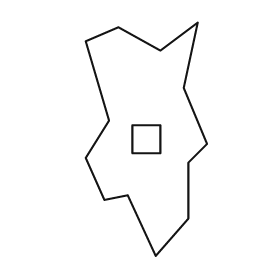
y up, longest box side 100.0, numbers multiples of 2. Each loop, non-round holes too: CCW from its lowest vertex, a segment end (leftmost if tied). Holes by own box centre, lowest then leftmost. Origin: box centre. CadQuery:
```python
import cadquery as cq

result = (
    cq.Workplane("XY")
    .moveTo(4.0, -50.0)
    .lineTo(18.0, -34.0)
    .lineTo(18.0, -10.0)
    .lineTo(26.0, -2.0)
    .lineTo(16.0, 22.0)
    .lineTo(22.0, 50.0)
    .lineTo(6.0, 38.0)
    .lineTo(-12.0, 48.0)
    .lineTo(-26.0, 42.0)
    .lineTo(-16.0, 8.0)
    .lineTo(-26.0, -8.0)
    .lineTo(-18.0, -26.0)
    .lineTo(-8.0, -24.0)
    .close()
    .moveTo(-6.0, -6.0)
    .lineTo(6.0, -6.0)
    .lineTo(6.0, 6.0)
    .lineTo(-6.0, 6.0)
    .close()
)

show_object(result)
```